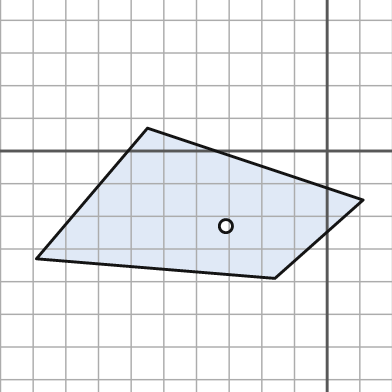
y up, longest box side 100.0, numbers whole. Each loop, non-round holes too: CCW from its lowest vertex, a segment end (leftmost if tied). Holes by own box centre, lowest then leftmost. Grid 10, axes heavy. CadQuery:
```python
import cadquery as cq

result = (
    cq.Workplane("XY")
    .moveTo(-16.0, -39.0)
    .lineTo(11.0, -15.0)
    .lineTo(-55.0, 7.0)
    .lineTo(-89.0, -33.0)
    .close()
    .moveTo(-31.0, -23.0)
    .circle(2.0)
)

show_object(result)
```